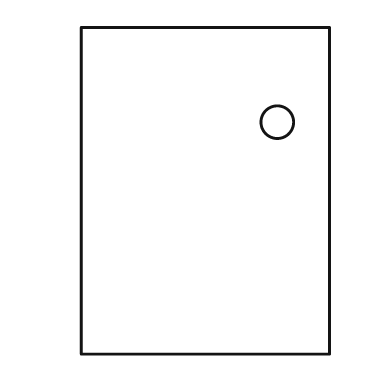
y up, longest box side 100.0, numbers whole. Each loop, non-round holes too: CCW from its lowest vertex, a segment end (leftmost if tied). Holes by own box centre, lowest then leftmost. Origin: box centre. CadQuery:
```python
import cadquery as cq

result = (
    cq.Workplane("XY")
    .moveTo(-38.0, -50.0)
    .lineTo(38.0, -50.0)
    .lineTo(38.0, 50.0)
    .lineTo(-38.0, 50.0)
    .close()
    .moveTo(22.0, 21.0)
    .circle(5.0)
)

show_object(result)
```